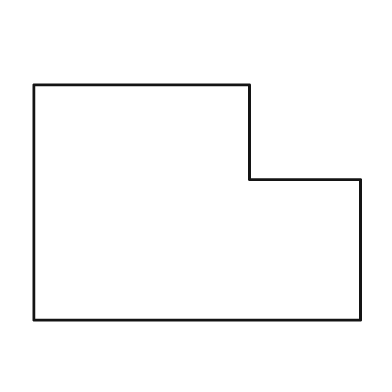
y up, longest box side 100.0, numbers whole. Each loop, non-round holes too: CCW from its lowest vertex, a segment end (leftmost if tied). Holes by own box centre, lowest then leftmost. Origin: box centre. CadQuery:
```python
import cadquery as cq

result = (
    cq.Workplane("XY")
    .moveTo(-50.0, -36.0)
    .lineTo(50.0, -36.0)
    .lineTo(50.0, 7.0)
    .lineTo(16.0, 7.0)
    .lineTo(16.0, 36.0)
    .lineTo(-50.0, 36.0)
    .close()
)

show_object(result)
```